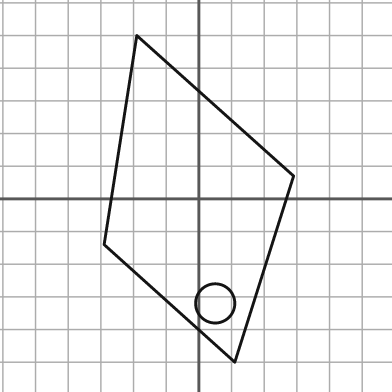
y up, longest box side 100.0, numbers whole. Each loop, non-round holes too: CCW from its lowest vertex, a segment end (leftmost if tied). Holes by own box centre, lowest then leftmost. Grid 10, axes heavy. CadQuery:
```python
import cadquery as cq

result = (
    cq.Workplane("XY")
    .moveTo(11.0, -50.0)
    .lineTo(29.0, 7.0)
    .lineTo(-19.0, 50.0)
    .lineTo(-29.0, -14.0)
    .close()
    .moveTo(5.0, -32.0)
    .circle(6.0)
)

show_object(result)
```